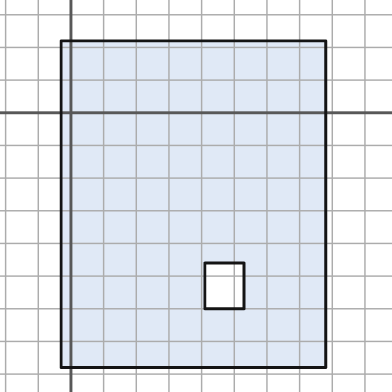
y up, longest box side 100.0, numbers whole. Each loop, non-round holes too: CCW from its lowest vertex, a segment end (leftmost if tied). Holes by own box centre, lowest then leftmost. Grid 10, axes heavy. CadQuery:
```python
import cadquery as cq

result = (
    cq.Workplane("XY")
    .moveTo(-3.0, -78.0)
    .lineTo(78.0, -78.0)
    .lineTo(78.0, 22.0)
    .lineTo(-3.0, 22.0)
    .close()
    .moveTo(41.0, -60.0)
    .lineTo(53.0, -60.0)
    .lineTo(53.0, -46.0)
    .lineTo(41.0, -46.0)
    .close()
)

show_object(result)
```